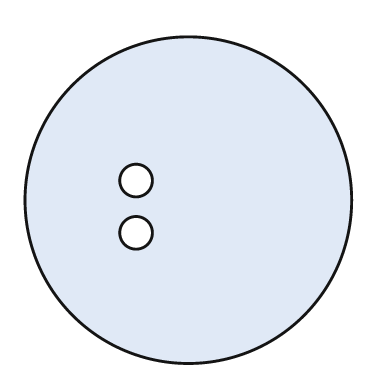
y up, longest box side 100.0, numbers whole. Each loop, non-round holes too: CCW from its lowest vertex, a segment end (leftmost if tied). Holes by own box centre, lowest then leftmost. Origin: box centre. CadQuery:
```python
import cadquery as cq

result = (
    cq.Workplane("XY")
    .moveTo(0.0, 0.0)
    .circle(50.0)
    .moveTo(-16.0, -10.0)
    .circle(5.0)
    .moveTo(-16.0, 6.0)
    .circle(5.0)
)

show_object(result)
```